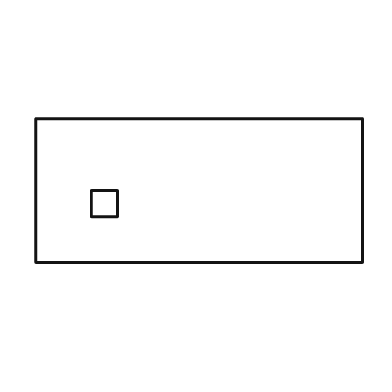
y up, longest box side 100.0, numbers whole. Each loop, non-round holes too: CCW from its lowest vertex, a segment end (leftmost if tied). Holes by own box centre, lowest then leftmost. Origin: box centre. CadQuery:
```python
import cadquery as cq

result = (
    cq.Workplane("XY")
    .moveTo(-50.0, -22.0)
    .lineTo(50.0, -22.0)
    .lineTo(50.0, 22.0)
    .lineTo(-50.0, 22.0)
    .close()
    .moveTo(-33.0, -8.0)
    .lineTo(-25.0, -8.0)
    .lineTo(-25.0, 0.0)
    .lineTo(-33.0, 0.0)
    .close()
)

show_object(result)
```